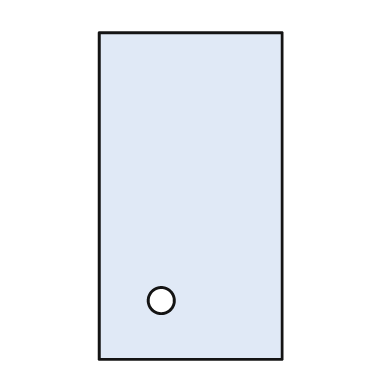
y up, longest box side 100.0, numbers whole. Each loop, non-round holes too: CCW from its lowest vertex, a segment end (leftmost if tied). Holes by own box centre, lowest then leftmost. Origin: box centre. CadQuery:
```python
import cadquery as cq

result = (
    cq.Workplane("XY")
    .moveTo(-28.0, -50.0)
    .lineTo(28.0, -50.0)
    .lineTo(28.0, 50.0)
    .lineTo(-28.0, 50.0)
    .close()
    .moveTo(-9.0, -32.0)
    .circle(4.0)
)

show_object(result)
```